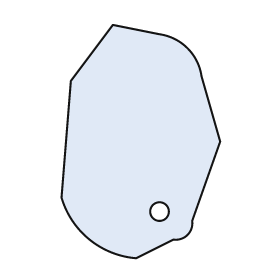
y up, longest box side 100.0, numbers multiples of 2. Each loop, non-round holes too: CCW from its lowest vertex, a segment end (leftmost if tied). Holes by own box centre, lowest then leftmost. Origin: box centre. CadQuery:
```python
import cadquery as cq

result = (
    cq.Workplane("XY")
    .moveTo(-2.0, -50.0)
    .lineTo(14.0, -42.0)
    .threePointArc((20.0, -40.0), (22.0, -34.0))
    .lineTo(34.0, 0.0)
    .lineTo(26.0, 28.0)
    .threePointArc((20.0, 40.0), (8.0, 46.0))
    .lineTo(-12.0, 50.0)
    .lineTo(-30.0, 26.0)
    .lineTo(-34.0, -24.0)
    .threePointArc((-22.0, -42.0), (-2.0, -50.0))
    .close()
    .moveTo(8.0, -30.0)
    .circle(4.0)
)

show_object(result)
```